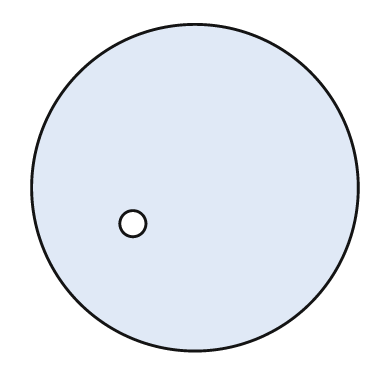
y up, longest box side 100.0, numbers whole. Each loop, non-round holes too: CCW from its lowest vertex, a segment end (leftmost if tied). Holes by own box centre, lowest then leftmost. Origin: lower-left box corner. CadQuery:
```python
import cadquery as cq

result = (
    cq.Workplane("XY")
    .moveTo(50.0, 50.0)
    .circle(50.0)
    .moveTo(31.0, 39.0)
    .circle(4.0)
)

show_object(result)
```